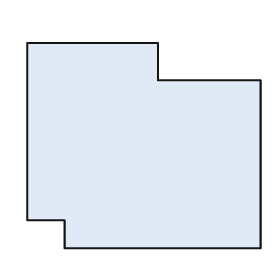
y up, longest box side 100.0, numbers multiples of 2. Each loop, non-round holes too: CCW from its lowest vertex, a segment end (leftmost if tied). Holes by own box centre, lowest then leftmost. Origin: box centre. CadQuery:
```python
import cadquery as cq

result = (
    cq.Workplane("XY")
    .moveTo(-34.0, -44.0)
    .lineTo(50.0, -44.0)
    .lineTo(50.0, 28.0)
    .lineTo(6.0, 28.0)
    .lineTo(6.0, 44.0)
    .lineTo(-50.0, 44.0)
    .lineTo(-50.0, -32.0)
    .lineTo(-34.0, -32.0)
    .close()
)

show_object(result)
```